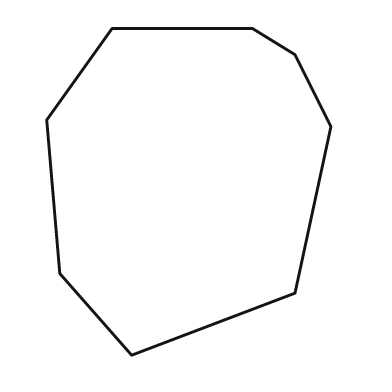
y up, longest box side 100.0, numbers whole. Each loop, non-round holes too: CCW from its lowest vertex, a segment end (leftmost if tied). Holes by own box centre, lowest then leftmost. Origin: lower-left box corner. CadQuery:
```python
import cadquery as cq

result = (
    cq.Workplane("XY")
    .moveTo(26.0, 0.0)
    .lineTo(76.0, 19.0)
    .lineTo(87.0, 70.0)
    .lineTo(76.0, 92.0)
    .lineTo(63.0, 100.0)
    .lineTo(20.0, 100.0)
    .lineTo(0.0, 72.0)
    .lineTo(4.0, 25.0)
    .close()
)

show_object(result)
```